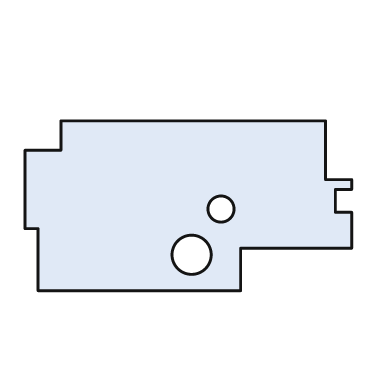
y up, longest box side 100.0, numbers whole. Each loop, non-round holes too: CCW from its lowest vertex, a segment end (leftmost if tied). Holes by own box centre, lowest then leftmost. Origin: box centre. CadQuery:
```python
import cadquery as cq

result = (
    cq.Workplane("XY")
    .moveTo(-46.0, -26.0)
    .lineTo(16.0, -26.0)
    .lineTo(16.0, -13.0)
    .lineTo(50.0, -13.0)
    .lineTo(50.0, -2.0)
    .lineTo(45.0, -2.0)
    .lineTo(45.0, 5.0)
    .lineTo(50.0, 5.0)
    .lineTo(50.0, 8.0)
    .lineTo(42.0, 8.0)
    .lineTo(42.0, 26.0)
    .lineTo(-39.0, 26.0)
    .lineTo(-39.0, 17.0)
    .lineTo(-50.0, 17.0)
    .lineTo(-50.0, -7.0)
    .lineTo(-46.0, -7.0)
    .close()
    .moveTo(1.0, -15.0)
    .circle(6.0)
    .moveTo(10.0, -1.0)
    .circle(4.0)
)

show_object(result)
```